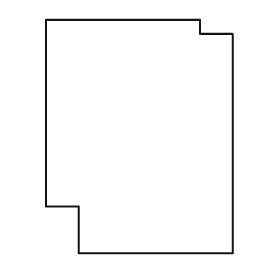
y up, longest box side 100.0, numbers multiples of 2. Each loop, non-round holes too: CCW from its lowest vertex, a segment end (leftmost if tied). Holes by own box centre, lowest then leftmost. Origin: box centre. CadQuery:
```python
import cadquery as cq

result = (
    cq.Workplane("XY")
    .moveTo(-26.0, -50.0)
    .lineTo(40.0, -50.0)
    .lineTo(40.0, 44.0)
    .lineTo(26.0, 44.0)
    .lineTo(26.0, 50.0)
    .lineTo(-40.0, 50.0)
    .lineTo(-40.0, -30.0)
    .lineTo(-26.0, -30.0)
    .close()
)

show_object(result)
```